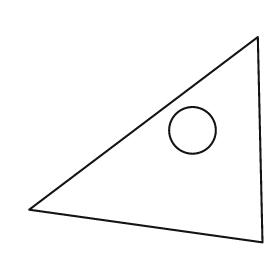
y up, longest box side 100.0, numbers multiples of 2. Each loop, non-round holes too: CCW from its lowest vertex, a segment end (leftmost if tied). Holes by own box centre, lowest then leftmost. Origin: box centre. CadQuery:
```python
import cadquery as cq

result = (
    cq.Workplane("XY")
    .moveTo(50.0, -44.0)
    .lineTo(48.0, 44.0)
    .lineTo(-50.0, -30.0)
    .close()
    .moveTo(20.0, 4.0)
    .circle(10.0)
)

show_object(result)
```